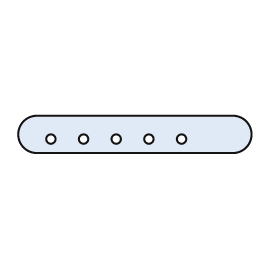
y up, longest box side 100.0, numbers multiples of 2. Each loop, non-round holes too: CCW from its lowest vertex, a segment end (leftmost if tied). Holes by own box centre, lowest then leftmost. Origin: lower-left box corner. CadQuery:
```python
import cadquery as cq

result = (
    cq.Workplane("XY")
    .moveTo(8.0, 0.0)
    .lineTo(92.0, 0.0)
    .threePointArc((100.0, 8.0), (92.0, 16.0))
    .lineTo(8.0, 16.0)
    .threePointArc((0.0, 8.0), (8.0, 0.0))
    .close()
    .moveTo(14.0, 6.0)
    .circle(2.0)
    .moveTo(28.0, 6.0)
    .circle(2.0)
    .moveTo(42.0, 6.0)
    .circle(2.0)
    .moveTo(56.0, 6.0)
    .circle(2.0)
    .moveTo(70.0, 6.0)
    .circle(2.0)
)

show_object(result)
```